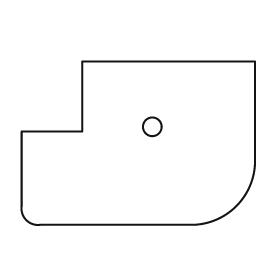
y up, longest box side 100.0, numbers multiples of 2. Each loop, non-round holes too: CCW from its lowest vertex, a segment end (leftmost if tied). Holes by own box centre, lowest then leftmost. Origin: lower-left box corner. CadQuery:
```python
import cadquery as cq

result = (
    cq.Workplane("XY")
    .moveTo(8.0, 0.0)
    .lineTo(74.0, 0.0)
    .threePointArc((92.0, 8.0), (100.0, 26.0))
    .lineTo(100.0, 70.0)
    .lineTo(26.0, 70.0)
    .lineTo(26.0, 40.0)
    .lineTo(0.0, 40.0)
    .lineTo(0.0, 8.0)
    .threePointArc((2.0, 2.0), (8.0, 0.0))
    .close()
    .moveTo(56.0, 42.0)
    .circle(4.0)
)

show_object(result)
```